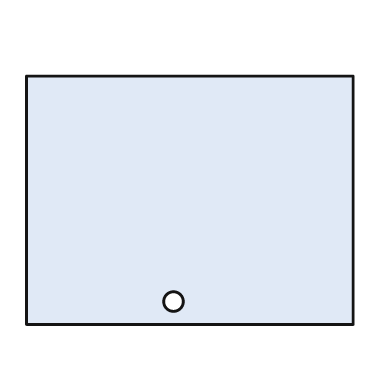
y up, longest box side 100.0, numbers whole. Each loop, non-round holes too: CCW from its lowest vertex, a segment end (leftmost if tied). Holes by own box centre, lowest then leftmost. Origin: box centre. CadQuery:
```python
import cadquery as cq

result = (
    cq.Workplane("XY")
    .moveTo(-50.0, -38.0)
    .lineTo(50.0, -38.0)
    .lineTo(50.0, 38.0)
    .lineTo(-50.0, 38.0)
    .close()
    .moveTo(-5.0, -31.0)
    .circle(3.0)
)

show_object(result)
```